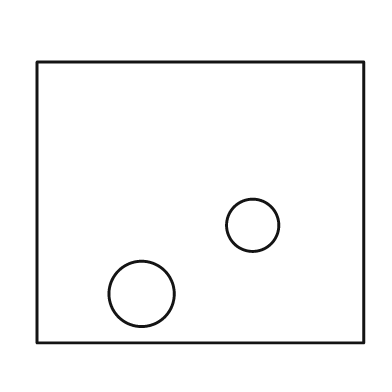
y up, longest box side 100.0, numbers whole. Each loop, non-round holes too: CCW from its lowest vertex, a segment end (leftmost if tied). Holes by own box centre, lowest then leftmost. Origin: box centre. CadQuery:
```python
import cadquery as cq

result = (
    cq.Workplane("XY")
    .moveTo(-50.0, -43.0)
    .lineTo(50.0, -43.0)
    .lineTo(50.0, 43.0)
    .lineTo(-50.0, 43.0)
    .close()
    .moveTo(-18.0, -28.0)
    .circle(10.0)
    .moveTo(16.0, -7.0)
    .circle(8.0)
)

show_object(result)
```